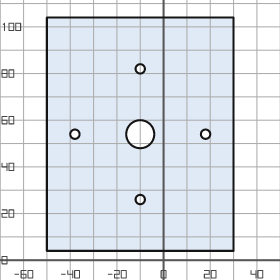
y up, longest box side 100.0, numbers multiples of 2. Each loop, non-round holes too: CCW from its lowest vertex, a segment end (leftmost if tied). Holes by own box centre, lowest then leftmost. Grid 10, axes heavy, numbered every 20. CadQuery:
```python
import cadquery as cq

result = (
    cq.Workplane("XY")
    .moveTo(-50.0, 4.0)
    .lineTo(30.0, 4.0)
    .lineTo(30.0, 104.0)
    .lineTo(-50.0, 104.0)
    .close()
    .moveTo(-10.0, 26.0)
    .circle(2.0)
    .moveTo(-38.0, 54.0)
    .circle(2.0)
    .moveTo(-10.0, 54.0)
    .circle(6.0)
    .moveTo(18.0, 54.0)
    .circle(2.0)
    .moveTo(-10.0, 82.0)
    .circle(2.0)
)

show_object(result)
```